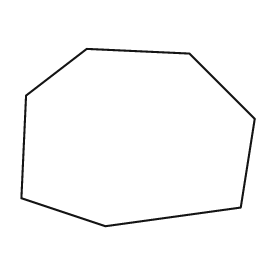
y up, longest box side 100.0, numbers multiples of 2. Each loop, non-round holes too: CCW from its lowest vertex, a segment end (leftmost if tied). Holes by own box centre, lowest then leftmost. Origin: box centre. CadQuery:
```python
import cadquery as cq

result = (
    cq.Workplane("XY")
    .moveTo(-14.0, -38.0)
    .lineTo(44.0, -30.0)
    .lineTo(50.0, 8.0)
    .lineTo(22.0, 36.0)
    .lineTo(-22.0, 38.0)
    .lineTo(-48.0, 18.0)
    .lineTo(-50.0, -26.0)
    .close()
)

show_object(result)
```